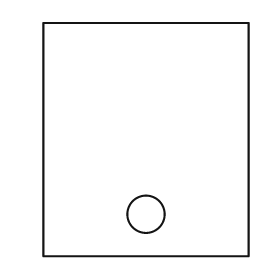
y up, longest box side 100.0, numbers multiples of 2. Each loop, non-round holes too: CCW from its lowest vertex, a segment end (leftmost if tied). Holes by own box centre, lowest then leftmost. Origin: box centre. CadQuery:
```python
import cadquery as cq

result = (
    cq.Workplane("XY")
    .moveTo(-44.0, -50.0)
    .lineTo(44.0, -50.0)
    .lineTo(44.0, 50.0)
    .lineTo(-44.0, 50.0)
    .close()
    .moveTo(0.0, -32.0)
    .circle(8.0)
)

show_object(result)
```